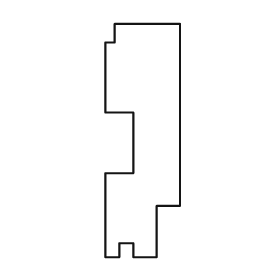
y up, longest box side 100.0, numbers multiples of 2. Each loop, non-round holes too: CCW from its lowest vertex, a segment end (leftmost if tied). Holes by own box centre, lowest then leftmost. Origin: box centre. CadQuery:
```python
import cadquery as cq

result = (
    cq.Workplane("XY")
    .moveTo(-16.0, -50.0)
    .lineTo(-10.0, -50.0)
    .lineTo(-10.0, -44.0)
    .lineTo(-4.0, -44.0)
    .lineTo(-4.0, -50.0)
    .lineTo(6.0, -50.0)
    .lineTo(6.0, -28.0)
    .lineTo(16.0, -28.0)
    .lineTo(16.0, 50.0)
    .lineTo(-12.0, 50.0)
    .lineTo(-12.0, 42.0)
    .lineTo(-16.0, 42.0)
    .lineTo(-16.0, 12.0)
    .lineTo(-4.0, 12.0)
    .lineTo(-4.0, -14.0)
    .lineTo(-16.0, -14.0)
    .close()
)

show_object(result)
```